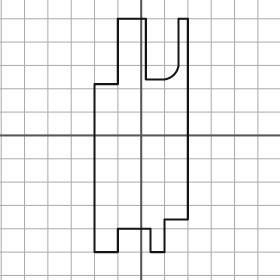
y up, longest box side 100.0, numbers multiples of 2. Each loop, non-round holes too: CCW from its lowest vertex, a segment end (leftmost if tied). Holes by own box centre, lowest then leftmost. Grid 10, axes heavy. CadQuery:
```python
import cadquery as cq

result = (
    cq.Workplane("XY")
    .moveTo(-20.0, -50.0)
    .lineTo(-10.0, -50.0)
    .lineTo(-10.0, -40.0)
    .lineTo(4.0, -40.0)
    .lineTo(4.0, -50.0)
    .lineTo(10.0, -50.0)
    .lineTo(10.0, -36.0)
    .lineTo(20.0, -36.0)
    .lineTo(20.0, 50.0)
    .lineTo(16.0, 50.0)
    .lineTo(16.0, 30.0)
    .threePointArc((14.0, 26.0), (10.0, 24.0))
    .lineTo(2.0, 24.0)
    .lineTo(2.0, 50.0)
    .lineTo(-10.0, 50.0)
    .lineTo(-10.0, 22.0)
    .lineTo(-20.0, 22.0)
    .close()
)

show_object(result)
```